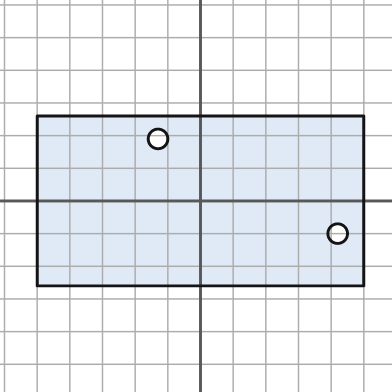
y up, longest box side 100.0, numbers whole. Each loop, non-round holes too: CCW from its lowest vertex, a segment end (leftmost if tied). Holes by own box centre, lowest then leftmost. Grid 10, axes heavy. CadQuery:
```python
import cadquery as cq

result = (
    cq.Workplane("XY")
    .moveTo(-50.0, -26.0)
    .lineTo(50.0, -26.0)
    .lineTo(50.0, 26.0)
    .lineTo(-50.0, 26.0)
    .close()
    .moveTo(42.0, -10.0)
    .circle(3.0)
    .moveTo(-13.0, 19.0)
    .circle(3.0)
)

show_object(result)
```